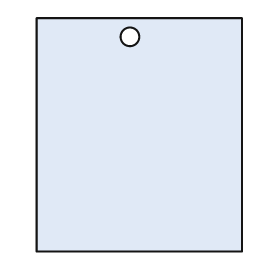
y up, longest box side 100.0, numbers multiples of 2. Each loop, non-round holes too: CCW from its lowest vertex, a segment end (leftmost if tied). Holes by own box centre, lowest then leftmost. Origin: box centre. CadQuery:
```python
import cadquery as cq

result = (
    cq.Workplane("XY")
    .moveTo(-44.0, -50.0)
    .lineTo(44.0, -50.0)
    .lineTo(44.0, 50.0)
    .lineTo(-44.0, 50.0)
    .close()
    .moveTo(-4.0, 42.0)
    .circle(4.0)
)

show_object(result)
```